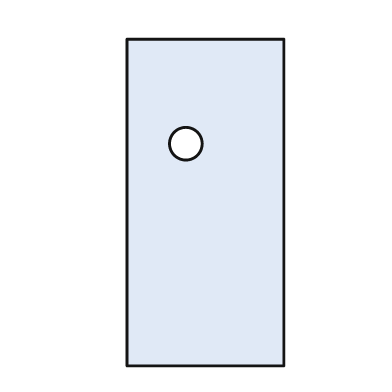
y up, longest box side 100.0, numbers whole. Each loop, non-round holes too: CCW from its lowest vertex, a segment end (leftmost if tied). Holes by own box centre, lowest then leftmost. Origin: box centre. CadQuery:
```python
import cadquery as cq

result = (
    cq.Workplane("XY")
    .moveTo(-24.0, -50.0)
    .lineTo(24.0, -50.0)
    .lineTo(24.0, 50.0)
    .lineTo(-24.0, 50.0)
    .close()
    .moveTo(-6.0, 18.0)
    .circle(5.0)
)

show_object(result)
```